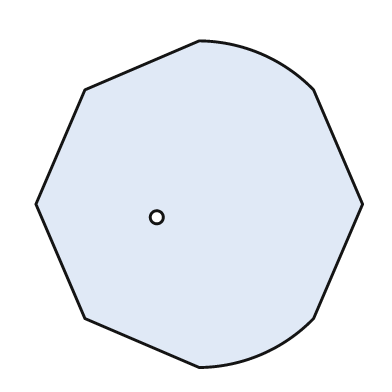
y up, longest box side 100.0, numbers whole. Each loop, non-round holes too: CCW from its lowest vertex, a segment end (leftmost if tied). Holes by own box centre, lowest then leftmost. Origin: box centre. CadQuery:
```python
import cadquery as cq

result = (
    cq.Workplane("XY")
    .moveTo(0.0, -50.0)
    .threePointArc((19.0, -46.0), (35.0, -35.0))
    .lineTo(50.0, 0.0)
    .lineTo(35.0, 35.0)
    .threePointArc((19.0, 46.0), (0.0, 50.0))
    .lineTo(-35.0, 35.0)
    .lineTo(-50.0, 0.0)
    .lineTo(-35.0, -35.0)
    .close()
    .moveTo(-13.0, -4.0)
    .circle(2.0)
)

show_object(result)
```